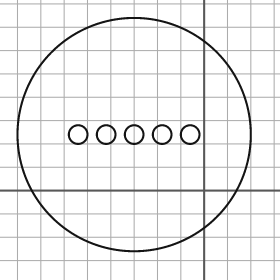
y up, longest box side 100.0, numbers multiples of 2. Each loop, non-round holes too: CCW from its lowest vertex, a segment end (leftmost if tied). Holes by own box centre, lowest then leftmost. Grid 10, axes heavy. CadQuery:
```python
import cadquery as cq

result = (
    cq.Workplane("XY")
    .moveTo(-30.0, 24.0)
    .circle(50.0)
    .moveTo(-54.0, 24.0)
    .circle(4.0)
    .moveTo(-42.0, 24.0)
    .circle(4.0)
    .moveTo(-30.0, 24.0)
    .circle(4.0)
    .moveTo(-18.0, 24.0)
    .circle(4.0)
    .moveTo(-6.0, 24.0)
    .circle(4.0)
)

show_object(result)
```